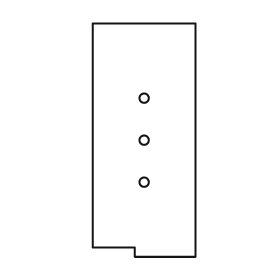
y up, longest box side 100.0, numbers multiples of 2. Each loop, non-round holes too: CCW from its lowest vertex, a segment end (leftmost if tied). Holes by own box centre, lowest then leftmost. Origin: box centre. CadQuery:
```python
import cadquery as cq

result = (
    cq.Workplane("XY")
    .moveTo(-4.0, -50.0)
    .lineTo(22.0, -50.0)
    .lineTo(22.0, 50.0)
    .lineTo(-22.0, 50.0)
    .lineTo(-22.0, -46.0)
    .lineTo(-4.0, -46.0)
    .close()
    .moveTo(0.0, -18.0)
    .circle(2.0)
    .moveTo(0.0, 0.0)
    .circle(2.0)
    .moveTo(0.0, 18.0)
    .circle(2.0)
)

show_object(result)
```